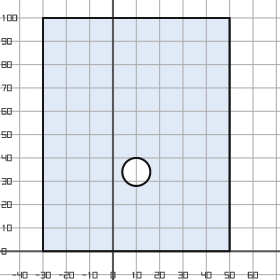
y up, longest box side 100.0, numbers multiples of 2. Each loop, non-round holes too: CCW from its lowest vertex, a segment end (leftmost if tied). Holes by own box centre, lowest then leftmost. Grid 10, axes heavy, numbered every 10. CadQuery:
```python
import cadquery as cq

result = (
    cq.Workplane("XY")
    .moveTo(-30.0, 0.0)
    .lineTo(50.0, 0.0)
    .lineTo(50.0, 100.0)
    .lineTo(-30.0, 100.0)
    .close()
    .moveTo(10.0, 34.0)
    .circle(6.0)
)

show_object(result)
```